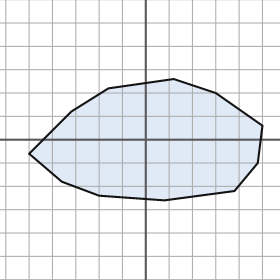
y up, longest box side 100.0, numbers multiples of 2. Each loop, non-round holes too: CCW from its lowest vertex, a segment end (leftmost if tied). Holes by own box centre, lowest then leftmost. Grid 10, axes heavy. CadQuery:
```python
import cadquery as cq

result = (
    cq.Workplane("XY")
    .moveTo(8.0, -26.0)
    .lineTo(38.0, -22.0)
    .lineTo(48.0, -10.0)
    .lineTo(50.0, 6.0)
    .lineTo(30.0, 20.0)
    .lineTo(12.0, 26.0)
    .lineTo(-16.0, 22.0)
    .lineTo(-32.0, 12.0)
    .lineTo(-50.0, -6.0)
    .lineTo(-36.0, -18.0)
    .lineTo(-20.0, -24.0)
    .close()
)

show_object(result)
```